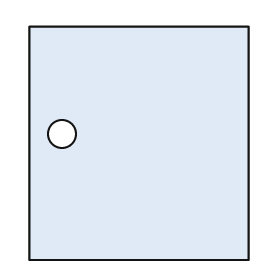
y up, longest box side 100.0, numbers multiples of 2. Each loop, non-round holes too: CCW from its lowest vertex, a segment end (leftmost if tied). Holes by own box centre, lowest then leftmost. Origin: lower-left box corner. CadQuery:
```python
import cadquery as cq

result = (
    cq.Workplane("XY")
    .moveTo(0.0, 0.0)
    .lineTo(94.0, 0.0)
    .lineTo(94.0, 100.0)
    .lineTo(0.0, 100.0)
    .close()
    .moveTo(14.0, 54.0)
    .circle(6.0)
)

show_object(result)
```